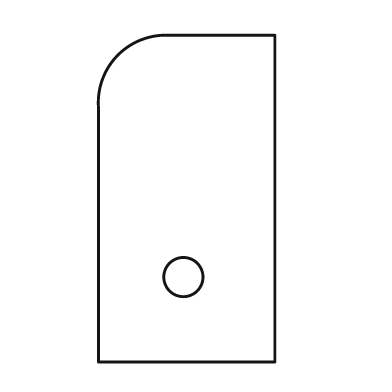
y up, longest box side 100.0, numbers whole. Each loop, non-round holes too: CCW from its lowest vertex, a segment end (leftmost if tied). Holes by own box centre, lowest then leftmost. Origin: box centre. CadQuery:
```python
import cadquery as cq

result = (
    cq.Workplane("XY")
    .moveTo(-27.0, -50.0)
    .lineTo(27.0, -50.0)
    .lineTo(27.0, 50.0)
    .lineTo(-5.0, 50.0)
    .threePointArc((-21.0, 44.0), (-27.0, 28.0))
    .close()
    .moveTo(-1.0, -24.0)
    .circle(6.0)
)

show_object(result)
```